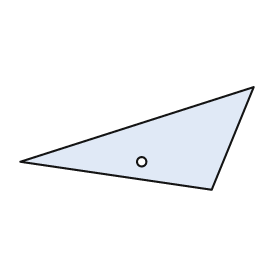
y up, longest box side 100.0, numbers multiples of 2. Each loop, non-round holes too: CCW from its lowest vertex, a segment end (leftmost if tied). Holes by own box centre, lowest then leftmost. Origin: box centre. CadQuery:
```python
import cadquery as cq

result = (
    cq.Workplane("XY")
    .moveTo(32.0, -22.0)
    .lineTo(50.0, 22.0)
    .lineTo(-50.0, -10.0)
    .close()
    .moveTo(2.0, -10.0)
    .circle(2.0)
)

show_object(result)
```